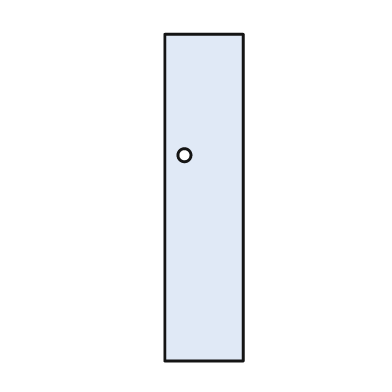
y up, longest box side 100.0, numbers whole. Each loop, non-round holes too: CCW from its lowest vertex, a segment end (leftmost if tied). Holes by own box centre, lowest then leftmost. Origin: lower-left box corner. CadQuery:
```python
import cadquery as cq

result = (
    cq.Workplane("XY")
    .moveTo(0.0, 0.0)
    .lineTo(24.0, 0.0)
    .lineTo(24.0, 100.0)
    .lineTo(0.0, 100.0)
    .close()
    .moveTo(6.0, 63.0)
    .circle(2.0)
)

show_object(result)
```